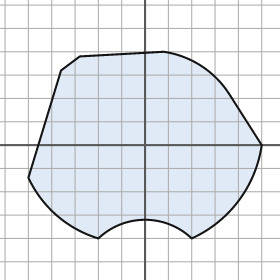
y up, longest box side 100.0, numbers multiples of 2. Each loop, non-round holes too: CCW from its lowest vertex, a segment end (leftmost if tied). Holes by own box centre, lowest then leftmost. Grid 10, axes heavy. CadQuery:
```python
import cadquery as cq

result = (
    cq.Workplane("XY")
    .moveTo(-20.0, -40.0)
    .threePointArc((0.0, -32.0), (20.0, -40.0))
    .threePointArc((40.0, -24.0), (50.0, 0.0))
    .lineTo(36.0, 22.0)
    .threePointArc((24.0, 34.0), (8.0, 40.0))
    .lineTo(-28.0, 38.0)
    .lineTo(-36.0, 32.0)
    .lineTo(-50.0, -14.0)
    .threePointArc((-38.0, -30.0), (-20.0, -40.0))
    .close()
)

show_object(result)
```